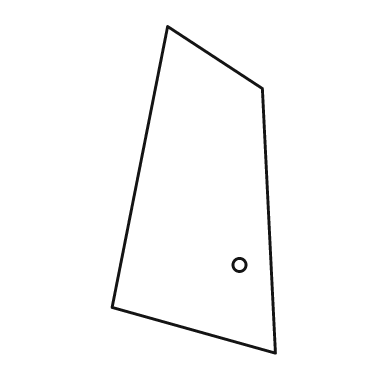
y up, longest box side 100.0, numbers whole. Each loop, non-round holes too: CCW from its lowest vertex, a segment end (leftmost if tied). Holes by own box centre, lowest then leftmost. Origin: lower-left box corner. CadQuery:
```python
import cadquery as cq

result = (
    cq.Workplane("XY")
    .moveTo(50.0, 0.0)
    .lineTo(46.0, 81.0)
    .lineTo(17.0, 100.0)
    .lineTo(0.0, 14.0)
    .close()
    .moveTo(39.0, 27.0)
    .circle(2.0)
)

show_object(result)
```